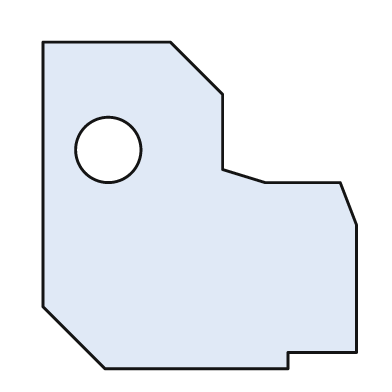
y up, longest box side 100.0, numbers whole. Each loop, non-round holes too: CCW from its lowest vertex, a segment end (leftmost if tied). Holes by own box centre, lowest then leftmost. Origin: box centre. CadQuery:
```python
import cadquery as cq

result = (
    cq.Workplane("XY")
    .moveTo(-29.0, -50.0)
    .lineTo(27.0, -50.0)
    .lineTo(27.0, -45.0)
    .lineTo(48.0, -45.0)
    .lineTo(48.0, -6.0)
    .lineTo(43.0, 7.0)
    .lineTo(20.0, 7.0)
    .lineTo(7.0, 11.0)
    .lineTo(7.0, 34.0)
    .lineTo(-9.0, 50.0)
    .lineTo(-48.0, 50.0)
    .lineTo(-48.0, -31.0)
    .close()
    .moveTo(-28.0, 17.0)
    .circle(10.0)
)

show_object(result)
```